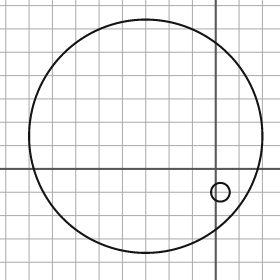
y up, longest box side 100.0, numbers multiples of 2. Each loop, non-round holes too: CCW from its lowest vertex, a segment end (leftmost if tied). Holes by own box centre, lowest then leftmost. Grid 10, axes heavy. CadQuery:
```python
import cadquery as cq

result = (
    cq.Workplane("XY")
    .moveTo(-30.0, 14.0)
    .circle(50.0)
    .moveTo(2.0, -10.0)
    .circle(4.0)
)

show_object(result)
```